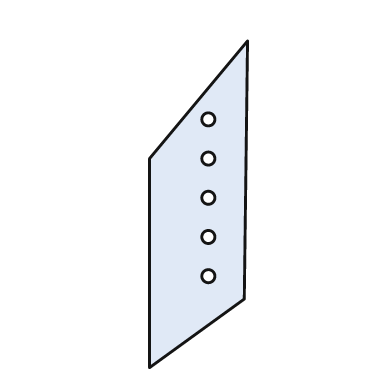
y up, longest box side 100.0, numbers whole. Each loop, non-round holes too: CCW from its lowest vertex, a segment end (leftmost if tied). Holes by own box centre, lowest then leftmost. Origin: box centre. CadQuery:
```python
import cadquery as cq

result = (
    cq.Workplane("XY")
    .moveTo(-15.0, -50.0)
    .lineTo(14.0, -29.0)
    .lineTo(15.0, 50.0)
    .lineTo(-15.0, 14.0)
    .close()
    .moveTo(3.0, -22.0)
    .circle(2.0)
    .moveTo(3.0, -10.0)
    .circle(2.0)
    .moveTo(3.0, 2.0)
    .circle(2.0)
    .moveTo(3.0, 14.0)
    .circle(2.0)
    .moveTo(3.0, 26.0)
    .circle(2.0)
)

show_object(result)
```